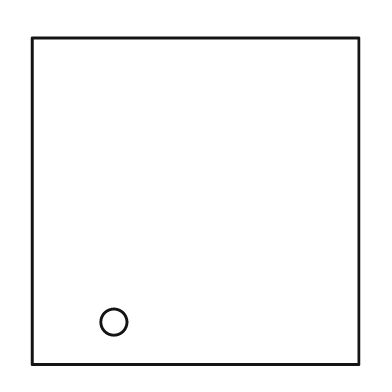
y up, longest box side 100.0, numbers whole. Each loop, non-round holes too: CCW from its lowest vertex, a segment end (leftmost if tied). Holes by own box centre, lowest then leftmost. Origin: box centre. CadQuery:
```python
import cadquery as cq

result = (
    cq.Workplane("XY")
    .moveTo(-50.0, -50.0)
    .lineTo(50.0, -50.0)
    .lineTo(50.0, 50.0)
    .lineTo(-50.0, 50.0)
    .close()
    .moveTo(-25.0, -37.0)
    .circle(4.0)
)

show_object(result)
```